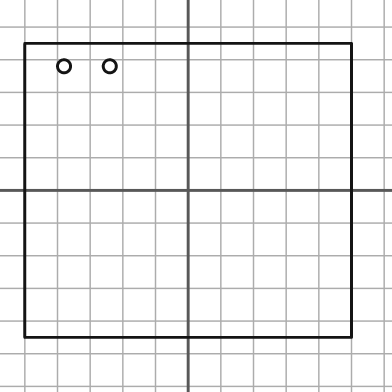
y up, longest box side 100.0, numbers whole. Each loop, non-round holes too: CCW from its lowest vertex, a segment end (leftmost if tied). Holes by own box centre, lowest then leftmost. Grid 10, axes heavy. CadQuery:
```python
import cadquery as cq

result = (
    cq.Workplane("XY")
    .moveTo(-50.0, -45.0)
    .lineTo(50.0, -45.0)
    .lineTo(50.0, 45.0)
    .lineTo(-50.0, 45.0)
    .close()
    .moveTo(-38.0, 38.0)
    .circle(2.0)
    .moveTo(-24.0, 38.0)
    .circle(2.0)
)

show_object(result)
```